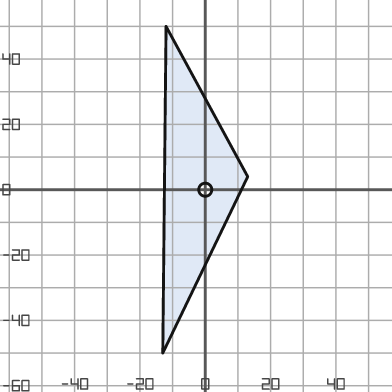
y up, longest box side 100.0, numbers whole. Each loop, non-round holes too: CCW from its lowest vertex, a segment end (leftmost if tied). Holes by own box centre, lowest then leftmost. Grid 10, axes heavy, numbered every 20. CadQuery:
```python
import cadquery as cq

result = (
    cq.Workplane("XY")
    .moveTo(-13.0, -50.0)
    .lineTo(13.0, 4.0)
    .lineTo(-12.0, 50.0)
    .close()
    .moveTo(0.0, 0.0)
    .circle(2.0)
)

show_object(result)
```